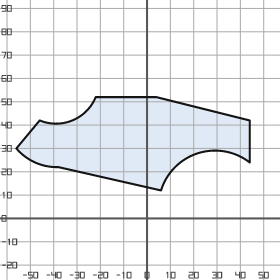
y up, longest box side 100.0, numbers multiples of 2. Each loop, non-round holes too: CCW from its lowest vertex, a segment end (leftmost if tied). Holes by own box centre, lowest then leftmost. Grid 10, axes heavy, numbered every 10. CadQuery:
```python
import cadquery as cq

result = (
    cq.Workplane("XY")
    .moveTo(6.0, 12.0)
    .threePointArc((22.0, 28.0), (44.0, 24.0))
    .lineTo(44.0, 42.0)
    .lineTo(4.0, 52.0)
    .lineTo(-22.0, 52.0)
    .threePointArc((-32.0, 42.0), (-46.0, 42.0))
    .lineTo(-56.0, 30.0)
    .threePointArc((-48.0, 24.0), (-38.0, 22.0))
    .close()
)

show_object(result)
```